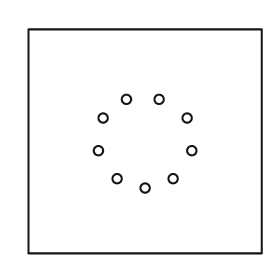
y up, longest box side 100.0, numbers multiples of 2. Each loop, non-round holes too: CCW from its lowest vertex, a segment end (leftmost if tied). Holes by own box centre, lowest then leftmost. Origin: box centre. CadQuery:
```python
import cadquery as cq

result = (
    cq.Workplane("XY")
    .moveTo(-50.0, -48.0)
    .lineTo(50.0, -48.0)
    .lineTo(50.0, 48.0)
    .lineTo(-50.0, 48.0)
    .close()
    .moveTo(0.0, -20.0)
    .circle(2.0)
    .moveTo(-12.0, -16.0)
    .circle(2.0)
    .moveTo(12.0, -16.0)
    .circle(2.0)
    .moveTo(-20.0, -4.0)
    .circle(2.0)
    .moveTo(20.0, -4.0)
    .circle(2.0)
    .moveTo(-18.0, 10.0)
    .circle(2.0)
    .moveTo(18.0, 10.0)
    .circle(2.0)
    .moveTo(-8.0, 18.0)
    .circle(2.0)
    .moveTo(6.0, 18.0)
    .circle(2.0)
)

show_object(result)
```